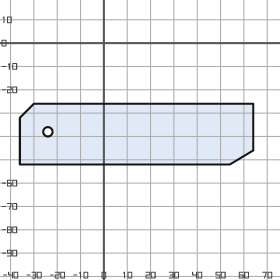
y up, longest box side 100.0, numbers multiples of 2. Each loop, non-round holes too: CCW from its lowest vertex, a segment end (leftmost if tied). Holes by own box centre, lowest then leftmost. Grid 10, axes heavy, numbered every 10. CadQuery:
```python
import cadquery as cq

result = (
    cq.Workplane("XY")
    .moveTo(-36.0, -52.0)
    .lineTo(54.0, -52.0)
    .lineTo(64.0, -46.0)
    .lineTo(64.0, -26.0)
    .lineTo(-30.0, -26.0)
    .lineTo(-36.0, -32.0)
    .close()
    .moveTo(-24.0, -38.0)
    .circle(2.0)
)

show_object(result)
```